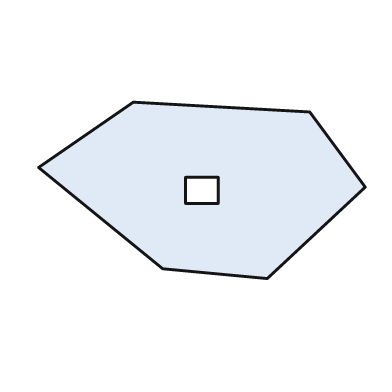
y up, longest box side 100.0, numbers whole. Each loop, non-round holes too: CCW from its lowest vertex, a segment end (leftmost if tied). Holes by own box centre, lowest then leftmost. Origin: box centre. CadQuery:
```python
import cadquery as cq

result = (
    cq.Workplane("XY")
    .moveTo(20.0, -27.0)
    .lineTo(50.0, 1.0)
    .lineTo(33.0, 24.0)
    .lineTo(-21.0, 27.0)
    .lineTo(-50.0, 7.0)
    .lineTo(-12.0, -24.0)
    .close()
    .moveTo(-5.0, -4.0)
    .lineTo(5.0, -4.0)
    .lineTo(5.0, 4.0)
    .lineTo(-5.0, 4.0)
    .close()
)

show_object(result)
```